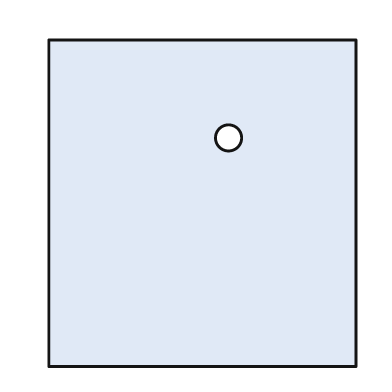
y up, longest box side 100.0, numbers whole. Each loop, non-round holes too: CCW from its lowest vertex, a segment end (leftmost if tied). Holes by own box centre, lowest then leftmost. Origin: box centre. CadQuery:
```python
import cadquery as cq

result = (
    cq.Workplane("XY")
    .moveTo(-47.0, -50.0)
    .lineTo(47.0, -50.0)
    .lineTo(47.0, 50.0)
    .lineTo(-47.0, 50.0)
    .close()
    .moveTo(8.0, 20.0)
    .circle(4.0)
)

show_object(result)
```